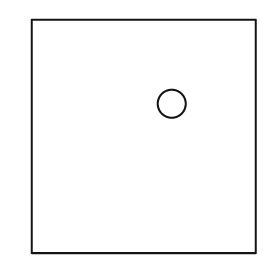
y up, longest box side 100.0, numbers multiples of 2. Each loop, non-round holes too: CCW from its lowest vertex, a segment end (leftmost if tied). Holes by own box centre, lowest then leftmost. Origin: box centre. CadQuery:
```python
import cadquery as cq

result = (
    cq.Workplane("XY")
    .moveTo(-48.0, -50.0)
    .lineTo(48.0, -50.0)
    .lineTo(48.0, 50.0)
    .lineTo(-48.0, 50.0)
    .close()
    .moveTo(12.0, 14.0)
    .circle(6.0)
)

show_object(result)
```